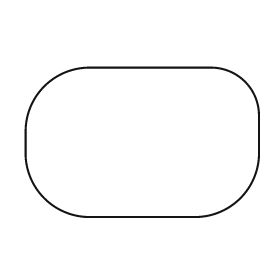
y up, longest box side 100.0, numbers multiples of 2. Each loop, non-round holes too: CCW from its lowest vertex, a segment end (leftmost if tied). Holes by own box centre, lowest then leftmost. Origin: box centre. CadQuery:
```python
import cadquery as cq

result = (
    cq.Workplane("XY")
    .moveTo(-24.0, -32.0)
    .lineTo(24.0, -32.0)
    .threePointArc((42.0, -24.0), (50.0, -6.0))
    .lineTo(50.0, 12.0)
    .threePointArc((44.0, 26.0), (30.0, 32.0))
    .lineTo(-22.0, 32.0)
    .threePointArc((-42.0, 24.0), (-50.0, 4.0))
    .lineTo(-50.0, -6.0)
    .threePointArc((-42.0, -24.0), (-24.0, -32.0))
    .close()
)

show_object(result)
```